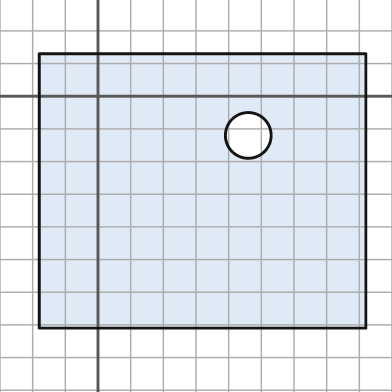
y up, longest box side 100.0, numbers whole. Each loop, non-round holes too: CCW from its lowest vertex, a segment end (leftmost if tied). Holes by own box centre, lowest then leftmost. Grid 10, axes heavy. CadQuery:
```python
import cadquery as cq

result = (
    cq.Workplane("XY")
    .moveTo(-18.0, -71.0)
    .lineTo(82.0, -71.0)
    .lineTo(82.0, 13.0)
    .lineTo(-18.0, 13.0)
    .close()
    .moveTo(46.0, -12.0)
    .circle(7.0)
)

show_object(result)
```